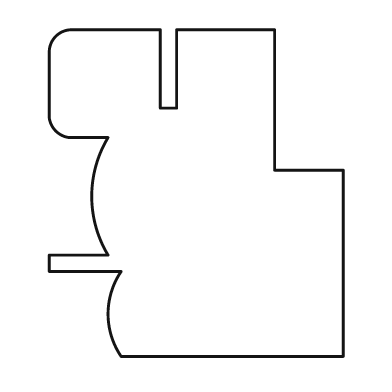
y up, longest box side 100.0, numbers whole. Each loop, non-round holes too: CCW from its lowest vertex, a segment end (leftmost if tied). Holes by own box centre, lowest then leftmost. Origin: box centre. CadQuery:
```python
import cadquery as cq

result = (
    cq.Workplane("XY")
    .moveTo(-23.0, -50.0)
    .lineTo(45.0, -50.0)
    .lineTo(45.0, 7.0)
    .lineTo(24.0, 7.0)
    .lineTo(24.0, 50.0)
    .lineTo(-6.0, 50.0)
    .lineTo(-6.0, 26.0)
    .lineTo(-11.0, 26.0)
    .lineTo(-11.0, 50.0)
    .lineTo(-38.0, 50.0)
    .threePointArc((-43.0, 48.0), (-45.0, 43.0))
    .lineTo(-45.0, 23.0)
    .threePointArc((-43.0, 19.0), (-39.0, 17.0))
    .lineTo(-27.0, 17.0)
    .threePointArc((-32.0, -1.0), (-27.0, -19.0))
    .lineTo(-45.0, -19.0)
    .lineTo(-45.0, -24.0)
    .lineTo(-23.0, -24.0)
    .threePointArc((-27.0, -37.0), (-23.0, -50.0))
    .close()
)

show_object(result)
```